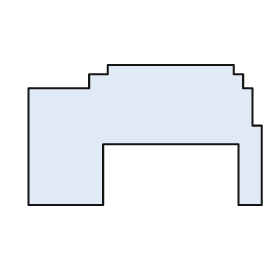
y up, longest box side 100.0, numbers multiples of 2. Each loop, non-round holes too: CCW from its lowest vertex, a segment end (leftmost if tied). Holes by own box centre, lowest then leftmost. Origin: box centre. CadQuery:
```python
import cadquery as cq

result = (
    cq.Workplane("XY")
    .moveTo(-50.0, -30.0)
    .lineTo(-18.0, -30.0)
    .lineTo(-18.0, -4.0)
    .lineTo(40.0, -4.0)
    .lineTo(40.0, -30.0)
    .lineTo(50.0, -30.0)
    .lineTo(50.0, 4.0)
    .lineTo(46.0, 4.0)
    .lineTo(46.0, 20.0)
    .lineTo(42.0, 20.0)
    .lineTo(42.0, 26.0)
    .lineTo(38.0, 26.0)
    .lineTo(38.0, 30.0)
    .lineTo(-16.0, 30.0)
    .lineTo(-16.0, 26.0)
    .lineTo(-24.0, 26.0)
    .lineTo(-24.0, 20.0)
    .lineTo(-50.0, 20.0)
    .close()
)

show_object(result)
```